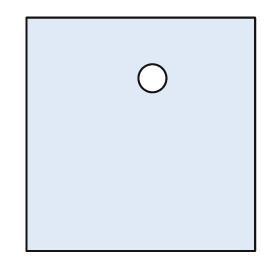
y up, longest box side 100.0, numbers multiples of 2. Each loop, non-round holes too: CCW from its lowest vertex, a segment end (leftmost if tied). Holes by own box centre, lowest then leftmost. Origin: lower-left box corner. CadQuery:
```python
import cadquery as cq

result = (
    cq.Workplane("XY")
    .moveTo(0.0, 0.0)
    .lineTo(98.0, 0.0)
    .lineTo(98.0, 100.0)
    .lineTo(0.0, 100.0)
    .close()
    .moveTo(54.0, 74.0)
    .circle(6.0)
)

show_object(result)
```